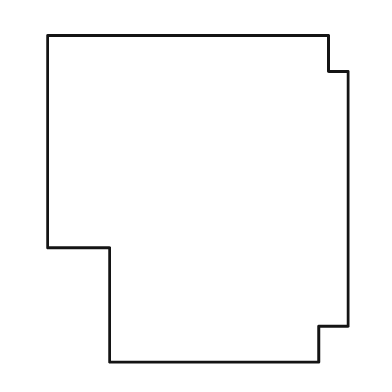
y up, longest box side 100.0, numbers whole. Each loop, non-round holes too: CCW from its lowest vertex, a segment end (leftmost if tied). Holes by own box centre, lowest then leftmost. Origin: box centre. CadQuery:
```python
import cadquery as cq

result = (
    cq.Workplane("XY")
    .moveTo(-27.0, -50.0)
    .lineTo(37.0, -50.0)
    .lineTo(37.0, -39.0)
    .lineTo(46.0, -39.0)
    .lineTo(46.0, 39.0)
    .lineTo(40.0, 39.0)
    .lineTo(40.0, 50.0)
    .lineTo(-46.0, 50.0)
    .lineTo(-46.0, -15.0)
    .lineTo(-27.0, -15.0)
    .close()
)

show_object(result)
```